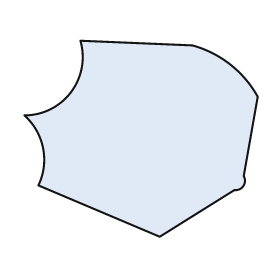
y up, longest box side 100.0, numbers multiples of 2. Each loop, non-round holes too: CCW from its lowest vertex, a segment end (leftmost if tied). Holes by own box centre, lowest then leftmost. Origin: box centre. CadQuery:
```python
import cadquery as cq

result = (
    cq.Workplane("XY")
    .moveTo(8.0, -42.0)
    .lineTo(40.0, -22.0)
    .threePointArc((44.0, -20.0), (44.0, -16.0))
    .lineTo(50.0, 18.0)
    .threePointArc((38.0, 32.0), (22.0, 40.0))
    .lineTo(-26.0, 42.0)
    .threePointArc((-30.0, 20.0), (-50.0, 10.0))
    .threePointArc((-42.0, -4.0), (-44.0, -20.0))
    .close()
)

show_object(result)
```